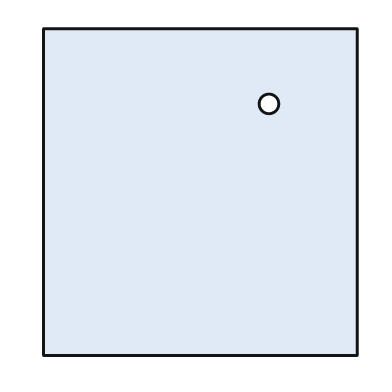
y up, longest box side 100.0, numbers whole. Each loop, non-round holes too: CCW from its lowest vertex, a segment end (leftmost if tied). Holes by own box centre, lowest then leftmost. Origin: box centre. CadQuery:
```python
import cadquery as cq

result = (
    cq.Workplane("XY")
    .moveTo(-48.0, -50.0)
    .lineTo(48.0, -50.0)
    .lineTo(48.0, 50.0)
    .lineTo(-48.0, 50.0)
    .close()
    .moveTo(21.0, 27.0)
    .circle(3.0)
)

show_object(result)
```